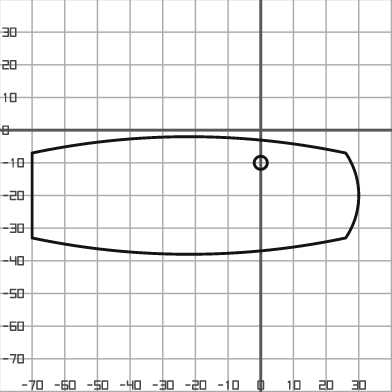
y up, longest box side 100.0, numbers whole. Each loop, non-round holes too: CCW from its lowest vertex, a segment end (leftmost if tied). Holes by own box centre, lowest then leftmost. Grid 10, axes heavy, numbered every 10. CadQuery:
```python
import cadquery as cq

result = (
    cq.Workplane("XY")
    .moveTo(-70.0, -33.0)
    .threePointArc((-22.0, -38.0), (26.0, -33.0))
    .threePointArc((30.0, -20.0), (26.0, -7.0))
    .threePointArc((-22.0, -2.0), (-70.0, -7.0))
    .close()
    .moveTo(0.0, -10.0)
    .circle(2.0)
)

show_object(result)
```